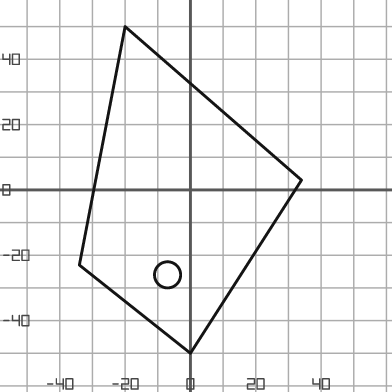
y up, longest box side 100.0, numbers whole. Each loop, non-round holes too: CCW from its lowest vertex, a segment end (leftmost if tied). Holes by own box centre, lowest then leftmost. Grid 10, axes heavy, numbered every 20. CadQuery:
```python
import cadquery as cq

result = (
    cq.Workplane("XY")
    .moveTo(0.0, -50.0)
    .lineTo(34.0, 3.0)
    .lineTo(-20.0, 50.0)
    .lineTo(-34.0, -23.0)
    .close()
    .moveTo(-7.0, -26.0)
    .circle(4.0)
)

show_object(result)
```